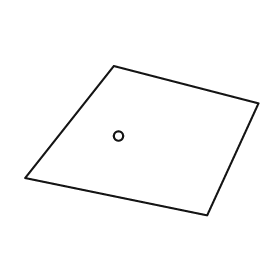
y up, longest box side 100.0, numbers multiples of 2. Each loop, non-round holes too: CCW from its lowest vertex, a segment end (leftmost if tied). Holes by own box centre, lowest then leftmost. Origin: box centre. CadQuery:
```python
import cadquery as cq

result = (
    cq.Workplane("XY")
    .moveTo(28.0, -32.0)
    .lineTo(50.0, 16.0)
    .lineTo(-12.0, 32.0)
    .lineTo(-50.0, -16.0)
    .close()
    .moveTo(-10.0, 2.0)
    .circle(2.0)
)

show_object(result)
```